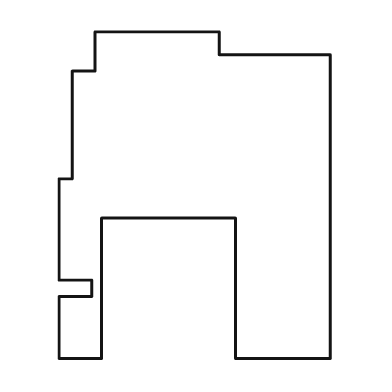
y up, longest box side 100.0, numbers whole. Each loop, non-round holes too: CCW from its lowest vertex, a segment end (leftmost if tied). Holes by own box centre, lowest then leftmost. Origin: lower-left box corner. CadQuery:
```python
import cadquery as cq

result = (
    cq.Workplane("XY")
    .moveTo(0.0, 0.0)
    .lineTo(13.0, 0.0)
    .lineTo(13.0, 43.0)
    .lineTo(54.0, 43.0)
    .lineTo(54.0, 0.0)
    .lineTo(83.0, 0.0)
    .lineTo(83.0, 93.0)
    .lineTo(49.0, 93.0)
    .lineTo(49.0, 100.0)
    .lineTo(11.0, 100.0)
    .lineTo(11.0, 88.0)
    .lineTo(4.0, 88.0)
    .lineTo(4.0, 55.0)
    .lineTo(0.0, 55.0)
    .lineTo(0.0, 24.0)
    .lineTo(10.0, 24.0)
    .lineTo(10.0, 19.0)
    .lineTo(0.0, 19.0)
    .close()
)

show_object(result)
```